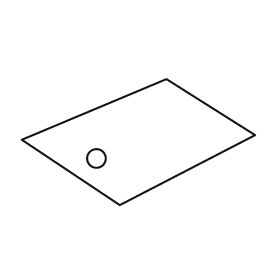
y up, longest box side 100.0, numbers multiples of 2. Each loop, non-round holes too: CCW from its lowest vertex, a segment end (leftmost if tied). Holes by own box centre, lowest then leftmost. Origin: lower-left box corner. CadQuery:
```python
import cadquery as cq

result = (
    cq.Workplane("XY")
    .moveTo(42.0, 0.0)
    .lineTo(100.0, 30.0)
    .lineTo(62.0, 54.0)
    .lineTo(0.0, 28.0)
    .close()
    .moveTo(32.0, 20.0)
    .circle(4.0)
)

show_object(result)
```